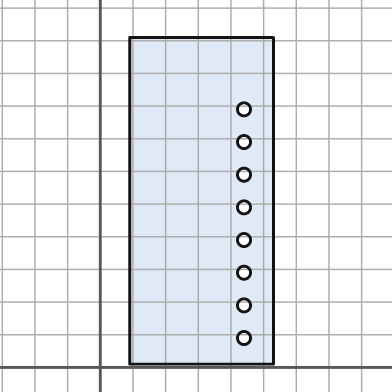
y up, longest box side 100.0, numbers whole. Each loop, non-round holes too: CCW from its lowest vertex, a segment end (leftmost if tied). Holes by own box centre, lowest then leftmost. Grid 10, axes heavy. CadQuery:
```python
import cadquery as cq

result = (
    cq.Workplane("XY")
    .moveTo(9.0, 1.0)
    .lineTo(53.0, 1.0)
    .lineTo(53.0, 101.0)
    .lineTo(9.0, 101.0)
    .close()
    .moveTo(44.0, 9.0)
    .circle(2.0)
    .moveTo(44.0, 19.0)
    .circle(2.0)
    .moveTo(44.0, 29.0)
    .circle(2.0)
    .moveTo(44.0, 39.0)
    .circle(2.0)
    .moveTo(44.0, 49.0)
    .circle(2.0)
    .moveTo(44.0, 59.0)
    .circle(2.0)
    .moveTo(44.0, 69.0)
    .circle(2.0)
    .moveTo(44.0, 79.0)
    .circle(2.0)
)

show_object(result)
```